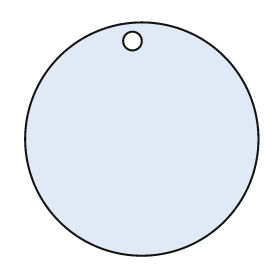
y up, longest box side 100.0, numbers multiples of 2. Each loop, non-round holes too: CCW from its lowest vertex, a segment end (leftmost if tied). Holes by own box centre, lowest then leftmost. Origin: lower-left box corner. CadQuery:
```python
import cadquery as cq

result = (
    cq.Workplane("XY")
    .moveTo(50.0, 50.0)
    .circle(50.0)
    .moveTo(46.0, 92.0)
    .circle(4.0)
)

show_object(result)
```